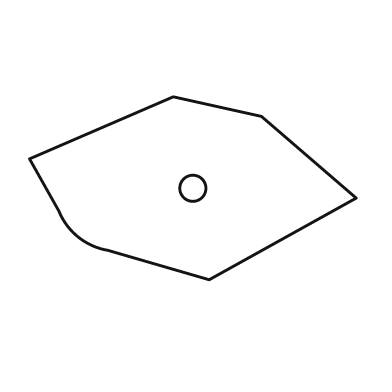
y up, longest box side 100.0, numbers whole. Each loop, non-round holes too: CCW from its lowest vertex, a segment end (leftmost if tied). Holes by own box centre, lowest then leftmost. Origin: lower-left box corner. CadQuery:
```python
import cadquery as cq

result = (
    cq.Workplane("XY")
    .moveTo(55.0, 0.0)
    .lineTo(100.0, 25.0)
    .lineTo(71.0, 50.0)
    .lineTo(44.0, 56.0)
    .lineTo(0.0, 37.0)
    .lineTo(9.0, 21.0)
    .threePointArc((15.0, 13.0), (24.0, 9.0))
    .close()
    .moveTo(50.0, 28.0)
    .circle(4.0)
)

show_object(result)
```